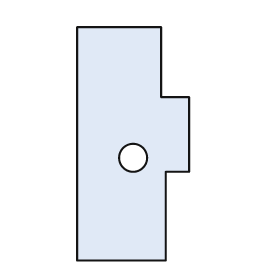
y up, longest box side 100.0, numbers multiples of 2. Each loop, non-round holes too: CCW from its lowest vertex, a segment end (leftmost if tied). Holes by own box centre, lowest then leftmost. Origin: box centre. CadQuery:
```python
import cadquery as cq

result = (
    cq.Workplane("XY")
    .moveTo(-24.0, -50.0)
    .lineTo(14.0, -50.0)
    .lineTo(14.0, -12.0)
    .lineTo(24.0, -12.0)
    .lineTo(24.0, 20.0)
    .lineTo(12.0, 20.0)
    .lineTo(12.0, 50.0)
    .lineTo(-24.0, 50.0)
    .close()
    .moveTo(0.0, -6.0)
    .circle(6.0)
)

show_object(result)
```